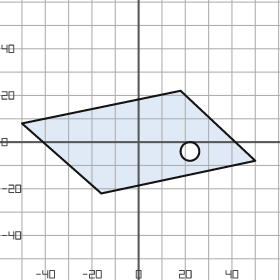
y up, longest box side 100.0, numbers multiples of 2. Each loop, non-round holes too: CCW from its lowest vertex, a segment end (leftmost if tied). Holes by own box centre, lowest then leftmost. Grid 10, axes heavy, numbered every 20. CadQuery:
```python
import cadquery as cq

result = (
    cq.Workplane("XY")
    .moveTo(-16.0, -22.0)
    .lineTo(50.0, -8.0)
    .lineTo(18.0, 22.0)
    .lineTo(-50.0, 8.0)
    .close()
    .moveTo(22.0, -4.0)
    .circle(4.0)
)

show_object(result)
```